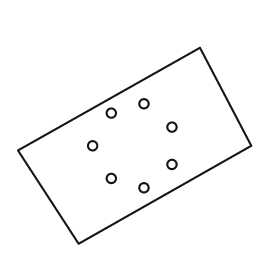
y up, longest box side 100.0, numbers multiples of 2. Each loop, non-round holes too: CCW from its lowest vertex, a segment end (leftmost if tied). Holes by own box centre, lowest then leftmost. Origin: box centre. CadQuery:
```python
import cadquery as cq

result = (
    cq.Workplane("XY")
    .moveTo(-24.0, -42.0)
    .lineTo(50.0, 0.0)
    .lineTo(28.0, 42.0)
    .lineTo(-50.0, -2.0)
    .close()
    .moveTo(4.0, -18.0)
    .circle(2.0)
    .moveTo(-10.0, -14.0)
    .circle(2.0)
    .moveTo(16.0, -8.0)
    .circle(2.0)
    .moveTo(-18.0, 0.0)
    .circle(2.0)
    .moveTo(16.0, 8.0)
    .circle(2.0)
    .moveTo(-10.0, 14.0)
    .circle(2.0)
    .moveTo(4.0, 18.0)
    .circle(2.0)
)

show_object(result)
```